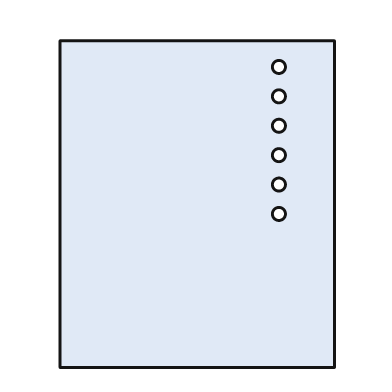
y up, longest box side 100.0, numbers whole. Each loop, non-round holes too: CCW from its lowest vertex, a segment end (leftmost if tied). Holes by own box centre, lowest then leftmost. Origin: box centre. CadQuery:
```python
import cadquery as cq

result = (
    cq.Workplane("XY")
    .moveTo(-42.0, -50.0)
    .lineTo(42.0, -50.0)
    .lineTo(42.0, 50.0)
    .lineTo(-42.0, 50.0)
    .close()
    .moveTo(25.0, -3.0)
    .circle(2.0)
    .moveTo(25.0, 6.0)
    .circle(2.0)
    .moveTo(25.0, 15.0)
    .circle(2.0)
    .moveTo(25.0, 24.0)
    .circle(2.0)
    .moveTo(25.0, 33.0)
    .circle(2.0)
    .moveTo(25.0, 42.0)
    .circle(2.0)
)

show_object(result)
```